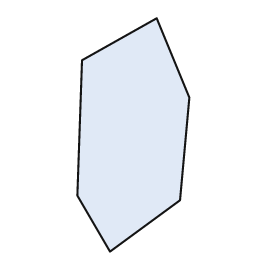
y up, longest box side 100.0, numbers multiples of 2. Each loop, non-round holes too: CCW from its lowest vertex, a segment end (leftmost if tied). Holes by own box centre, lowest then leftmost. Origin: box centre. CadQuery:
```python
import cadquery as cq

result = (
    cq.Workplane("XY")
    .moveTo(-10.0, -50.0)
    .lineTo(20.0, -28.0)
    .lineTo(24.0, 16.0)
    .lineTo(10.0, 50.0)
    .lineTo(-22.0, 32.0)
    .lineTo(-24.0, -26.0)
    .close()
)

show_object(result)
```